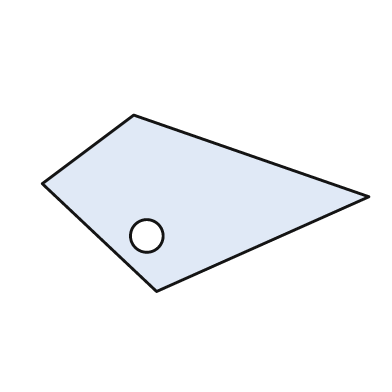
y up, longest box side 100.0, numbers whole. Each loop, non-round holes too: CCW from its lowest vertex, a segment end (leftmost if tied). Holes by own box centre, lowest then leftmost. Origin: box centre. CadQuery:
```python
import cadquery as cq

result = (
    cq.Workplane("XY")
    .moveTo(-15.0, -27.0)
    .lineTo(50.0, 2.0)
    .lineTo(-22.0, 27.0)
    .lineTo(-50.0, 6.0)
    .close()
    .moveTo(-18.0, -10.0)
    .circle(5.0)
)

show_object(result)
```